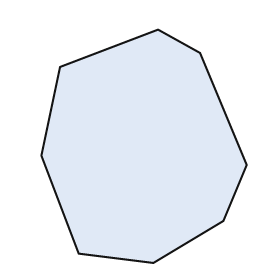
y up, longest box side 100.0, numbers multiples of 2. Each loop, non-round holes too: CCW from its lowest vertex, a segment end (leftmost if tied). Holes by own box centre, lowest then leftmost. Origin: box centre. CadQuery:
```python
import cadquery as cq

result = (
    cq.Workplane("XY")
    .moveTo(4.0, -50.0)
    .lineTo(34.0, -32.0)
    .lineTo(44.0, -8.0)
    .lineTo(24.0, 40.0)
    .lineTo(6.0, 50.0)
    .lineTo(-36.0, 34.0)
    .lineTo(-44.0, -4.0)
    .lineTo(-28.0, -46.0)
    .close()
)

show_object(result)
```